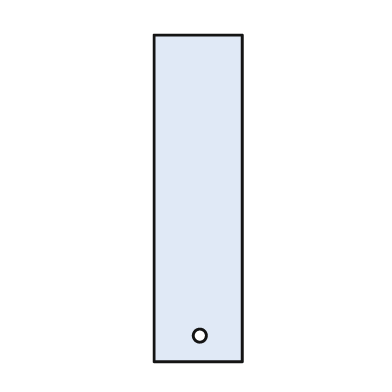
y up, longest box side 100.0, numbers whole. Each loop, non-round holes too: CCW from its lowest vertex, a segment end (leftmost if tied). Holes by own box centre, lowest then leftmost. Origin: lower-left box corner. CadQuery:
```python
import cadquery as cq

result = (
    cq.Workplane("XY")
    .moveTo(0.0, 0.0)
    .lineTo(27.0, 0.0)
    .lineTo(27.0, 100.0)
    .lineTo(0.0, 100.0)
    .close()
    .moveTo(14.0, 8.0)
    .circle(2.0)
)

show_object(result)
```